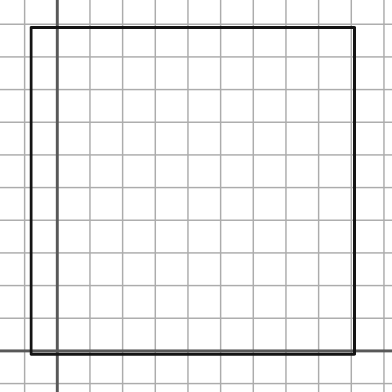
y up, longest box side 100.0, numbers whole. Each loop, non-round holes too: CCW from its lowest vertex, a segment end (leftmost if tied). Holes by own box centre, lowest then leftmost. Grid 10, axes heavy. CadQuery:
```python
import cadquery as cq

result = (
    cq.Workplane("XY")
    .moveTo(-8.0, -1.0)
    .lineTo(91.0, -1.0)
    .lineTo(91.0, 99.0)
    .lineTo(-8.0, 99.0)
    .close()
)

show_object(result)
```